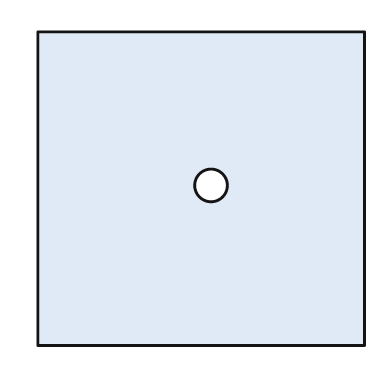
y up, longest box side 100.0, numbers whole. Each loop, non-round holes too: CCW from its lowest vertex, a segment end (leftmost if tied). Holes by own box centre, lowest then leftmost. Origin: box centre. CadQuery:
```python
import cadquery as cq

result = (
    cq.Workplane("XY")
    .moveTo(-50.0, -48.0)
    .lineTo(50.0, -48.0)
    .lineTo(50.0, 48.0)
    .lineTo(-50.0, 48.0)
    .close()
    .moveTo(3.0, 1.0)
    .circle(5.0)
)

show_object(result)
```